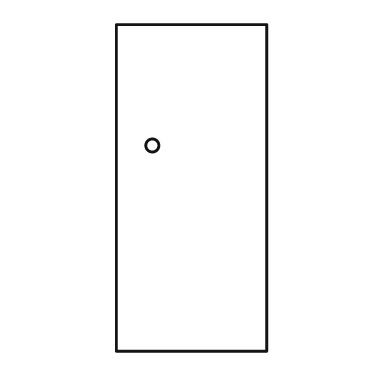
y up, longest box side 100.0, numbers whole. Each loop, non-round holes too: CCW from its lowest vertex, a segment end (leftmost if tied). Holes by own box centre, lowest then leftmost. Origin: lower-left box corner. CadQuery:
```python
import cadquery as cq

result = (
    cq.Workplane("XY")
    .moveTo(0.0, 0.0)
    .lineTo(46.0, 0.0)
    .lineTo(46.0, 100.0)
    .lineTo(0.0, 100.0)
    .close()
    .moveTo(11.0, 63.0)
    .circle(2.0)
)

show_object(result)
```